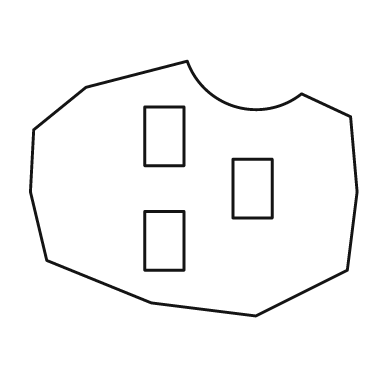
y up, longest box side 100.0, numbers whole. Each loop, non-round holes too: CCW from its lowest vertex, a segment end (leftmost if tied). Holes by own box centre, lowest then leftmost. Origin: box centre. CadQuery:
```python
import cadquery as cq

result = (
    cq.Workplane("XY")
    .moveTo(19.0, -39.0)
    .lineTo(47.0, -25.0)
    .lineTo(50.0, -1.0)
    .lineTo(48.0, 22.0)
    .lineTo(33.0, 29.0)
    .threePointArc((13.0, 25.0), (-2.0, 39.0))
    .lineTo(-33.0, 31.0)
    .lineTo(-49.0, 18.0)
    .lineTo(-50.0, -1.0)
    .lineTo(-45.0, -22.0)
    .lineTo(-13.0, -35.0)
    .close()
    .moveTo(-15.0, -25.0)
    .lineTo(-3.0, -25.0)
    .lineTo(-3.0, -7.0)
    .lineTo(-15.0, -7.0)
    .close()
    .moveTo(12.0, -9.0)
    .lineTo(24.0, -9.0)
    .lineTo(24.0, 9.0)
    .lineTo(12.0, 9.0)
    .close()
    .moveTo(-15.0, 7.0)
    .lineTo(-3.0, 7.0)
    .lineTo(-3.0, 25.0)
    .lineTo(-15.0, 25.0)
    .close()
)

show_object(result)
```